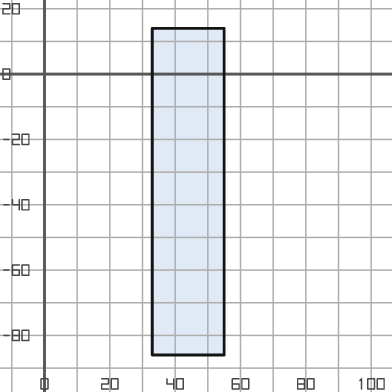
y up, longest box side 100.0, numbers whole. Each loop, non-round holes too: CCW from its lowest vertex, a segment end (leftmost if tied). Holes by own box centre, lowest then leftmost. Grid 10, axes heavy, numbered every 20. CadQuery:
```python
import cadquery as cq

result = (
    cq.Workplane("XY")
    .moveTo(33.0, -86.0)
    .lineTo(55.0, -86.0)
    .lineTo(55.0, 14.0)
    .lineTo(33.0, 14.0)
    .close()
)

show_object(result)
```